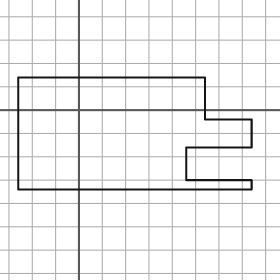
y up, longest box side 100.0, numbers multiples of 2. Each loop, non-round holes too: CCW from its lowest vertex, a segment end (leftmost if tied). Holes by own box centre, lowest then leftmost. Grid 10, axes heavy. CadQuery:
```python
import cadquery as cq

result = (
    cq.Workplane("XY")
    .moveTo(-26.0, -34.0)
    .lineTo(74.0, -34.0)
    .lineTo(74.0, -30.0)
    .lineTo(46.0, -30.0)
    .lineTo(46.0, -16.0)
    .lineTo(74.0, -16.0)
    .lineTo(74.0, -4.0)
    .lineTo(54.0, -4.0)
    .lineTo(54.0, 14.0)
    .lineTo(-26.0, 14.0)
    .close()
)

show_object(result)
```